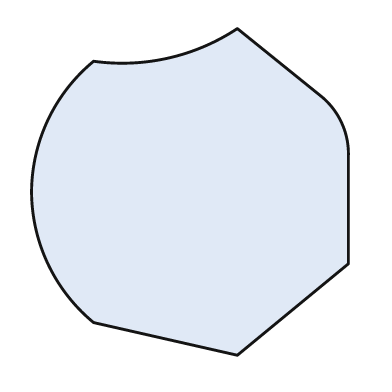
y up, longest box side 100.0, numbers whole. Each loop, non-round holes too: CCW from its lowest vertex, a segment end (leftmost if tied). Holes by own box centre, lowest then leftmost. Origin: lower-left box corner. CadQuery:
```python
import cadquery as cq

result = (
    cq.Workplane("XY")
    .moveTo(63.0, 0.0)
    .lineTo(97.0, 28.0)
    .lineTo(97.0, 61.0)
    .threePointArc((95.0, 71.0), (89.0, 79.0))
    .lineTo(63.0, 100.0)
    .threePointArc((42.0, 91.0), (19.0, 90.0))
    .threePointArc((5.0, 72.0), (0.0, 50.0))
    .threePointArc((5.0, 28.0), (19.0, 10.0))
    .close()
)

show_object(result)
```